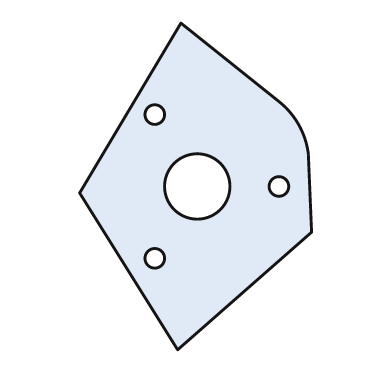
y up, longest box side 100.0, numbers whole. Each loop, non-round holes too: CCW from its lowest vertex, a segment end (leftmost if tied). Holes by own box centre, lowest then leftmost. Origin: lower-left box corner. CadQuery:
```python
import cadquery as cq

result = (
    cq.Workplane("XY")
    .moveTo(30.0, 0.0)
    .lineTo(71.0, 36.0)
    .lineTo(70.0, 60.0)
    .threePointArc((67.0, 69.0), (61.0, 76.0))
    .lineTo(31.0, 100.0)
    .lineTo(0.0, 48.0)
    .close()
    .moveTo(23.0, 28.0)
    .circle(3.0)
    .moveTo(36.0, 50.0)
    .circle(10.0)
    .moveTo(61.0, 50.0)
    .circle(3.0)
    .moveTo(23.0, 72.0)
    .circle(3.0)
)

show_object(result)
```